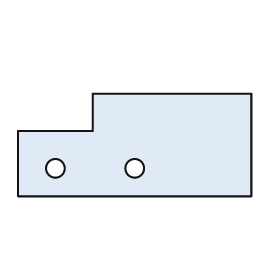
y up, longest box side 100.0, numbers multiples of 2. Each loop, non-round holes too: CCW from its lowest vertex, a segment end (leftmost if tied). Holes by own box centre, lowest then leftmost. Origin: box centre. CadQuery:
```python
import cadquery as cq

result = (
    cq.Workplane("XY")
    .moveTo(-50.0, -22.0)
    .lineTo(50.0, -22.0)
    .lineTo(50.0, 22.0)
    .lineTo(-18.0, 22.0)
    .lineTo(-18.0, 6.0)
    .lineTo(-50.0, 6.0)
    .close()
    .moveTo(-34.0, -10.0)
    .circle(4.0)
    .moveTo(0.0, -10.0)
    .circle(4.0)
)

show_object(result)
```